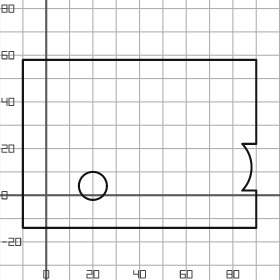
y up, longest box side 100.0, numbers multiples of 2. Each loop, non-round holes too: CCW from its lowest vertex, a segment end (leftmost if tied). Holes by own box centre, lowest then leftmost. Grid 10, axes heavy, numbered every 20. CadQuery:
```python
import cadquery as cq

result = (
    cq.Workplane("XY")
    .moveTo(-10.0, -14.0)
    .lineTo(90.0, -14.0)
    .lineTo(90.0, 2.0)
    .lineTo(84.0, 2.0)
    .threePointArc((88.0, 12.0), (84.0, 22.0))
    .lineTo(90.0, 22.0)
    .lineTo(90.0, 58.0)
    .lineTo(-10.0, 58.0)
    .close()
    .moveTo(20.0, 4.0)
    .circle(6.0)
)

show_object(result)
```